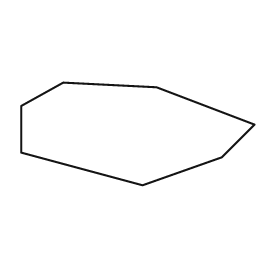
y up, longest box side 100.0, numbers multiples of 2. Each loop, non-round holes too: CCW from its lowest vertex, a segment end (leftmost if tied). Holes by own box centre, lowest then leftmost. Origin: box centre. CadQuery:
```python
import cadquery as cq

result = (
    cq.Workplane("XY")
    .moveTo(2.0, -22.0)
    .lineTo(36.0, -10.0)
    .lineTo(50.0, 4.0)
    .lineTo(8.0, 20.0)
    .lineTo(-32.0, 22.0)
    .lineTo(-50.0, 12.0)
    .lineTo(-50.0, -8.0)
    .close()
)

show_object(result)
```